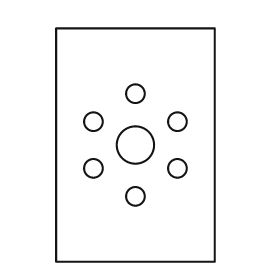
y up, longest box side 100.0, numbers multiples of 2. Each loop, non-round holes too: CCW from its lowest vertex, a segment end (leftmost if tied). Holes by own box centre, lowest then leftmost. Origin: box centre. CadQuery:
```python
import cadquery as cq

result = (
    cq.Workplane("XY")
    .moveTo(-34.0, -50.0)
    .lineTo(34.0, -50.0)
    .lineTo(34.0, 50.0)
    .lineTo(-34.0, 50.0)
    .close()
    .moveTo(0.0, -22.0)
    .circle(4.0)
    .moveTo(-18.0, -10.0)
    .circle(4.0)
    .moveTo(18.0, -10.0)
    .circle(4.0)
    .moveTo(0.0, 0.0)
    .circle(8.0)
    .moveTo(-18.0, 10.0)
    .circle(4.0)
    .moveTo(18.0, 10.0)
    .circle(4.0)
    .moveTo(0.0, 22.0)
    .circle(4.0)
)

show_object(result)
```